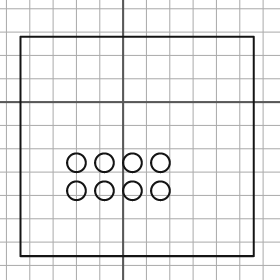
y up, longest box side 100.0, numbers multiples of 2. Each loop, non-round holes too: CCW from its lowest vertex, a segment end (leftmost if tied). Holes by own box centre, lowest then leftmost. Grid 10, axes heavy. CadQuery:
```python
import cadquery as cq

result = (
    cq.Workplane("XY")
    .moveTo(-44.0, -66.0)
    .lineTo(56.0, -66.0)
    .lineTo(56.0, 28.0)
    .lineTo(-44.0, 28.0)
    .close()
    .moveTo(-20.0, -38.0)
    .circle(4.0)
    .moveTo(-8.0, -38.0)
    .circle(4.0)
    .moveTo(4.0, -38.0)
    .circle(4.0)
    .moveTo(16.0, -38.0)
    .circle(4.0)
    .moveTo(-20.0, -26.0)
    .circle(4.0)
    .moveTo(-8.0, -26.0)
    .circle(4.0)
    .moveTo(4.0, -26.0)
    .circle(4.0)
    .moveTo(16.0, -26.0)
    .circle(4.0)
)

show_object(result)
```